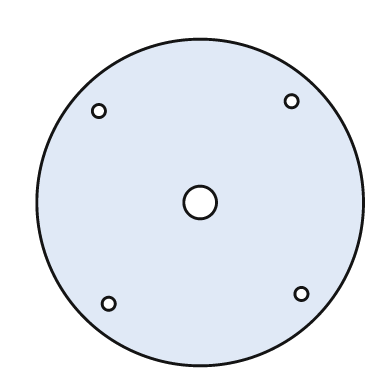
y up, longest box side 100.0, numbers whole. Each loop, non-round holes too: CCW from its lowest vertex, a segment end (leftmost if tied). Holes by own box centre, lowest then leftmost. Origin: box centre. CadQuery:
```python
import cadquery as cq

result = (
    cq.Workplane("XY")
    .moveTo(0.0, 0.0)
    .circle(50.0)
    .moveTo(-28.0, -31.0)
    .circle(2.0)
    .moveTo(31.0, -28.0)
    .circle(2.0)
    .moveTo(0.0, 0.0)
    .circle(5.0)
    .moveTo(-31.0, 28.0)
    .circle(2.0)
    .moveTo(28.0, 31.0)
    .circle(2.0)
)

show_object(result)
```